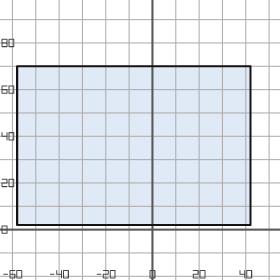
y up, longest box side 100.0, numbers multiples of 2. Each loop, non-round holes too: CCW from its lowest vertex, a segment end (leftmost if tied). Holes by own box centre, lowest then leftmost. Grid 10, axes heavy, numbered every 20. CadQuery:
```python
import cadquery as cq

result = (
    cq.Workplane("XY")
    .moveTo(-58.0, 2.0)
    .lineTo(42.0, 2.0)
    .lineTo(42.0, 70.0)
    .lineTo(-58.0, 70.0)
    .close()
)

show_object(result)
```